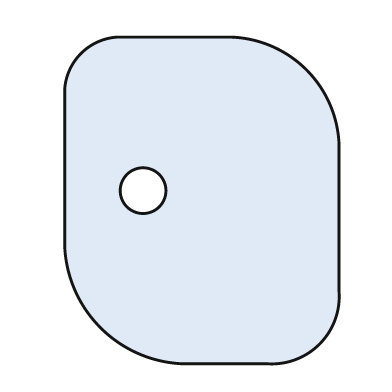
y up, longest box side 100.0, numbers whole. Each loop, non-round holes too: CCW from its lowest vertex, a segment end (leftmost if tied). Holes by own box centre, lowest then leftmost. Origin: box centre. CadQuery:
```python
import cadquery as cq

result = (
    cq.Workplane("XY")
    .moveTo(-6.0, -50.0)
    .lineTo(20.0, -50.0)
    .threePointArc((36.0, -44.0), (42.0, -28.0))
    .lineTo(42.0, 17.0)
    .threePointArc((32.0, 40.0), (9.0, 50.0))
    .lineTo(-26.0, 50.0)
    .threePointArc((-37.0, 45.0), (-42.0, 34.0))
    .lineTo(-42.0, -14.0)
    .threePointArc((-31.0, -39.0), (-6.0, -50.0))
    .close()
    .moveTo(-18.0, 3.0)
    .circle(7.0)
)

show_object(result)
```